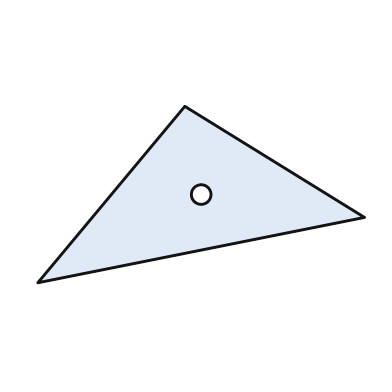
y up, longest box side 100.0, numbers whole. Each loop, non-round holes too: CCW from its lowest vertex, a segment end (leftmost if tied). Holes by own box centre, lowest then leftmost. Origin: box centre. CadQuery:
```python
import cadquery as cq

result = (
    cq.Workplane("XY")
    .moveTo(-50.0, -27.0)
    .lineTo(50.0, -7.0)
    .lineTo(-5.0, 27.0)
    .close()
    .moveTo(0.0, 0.0)
    .circle(3.0)
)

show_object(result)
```